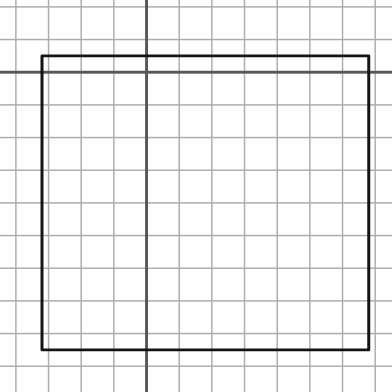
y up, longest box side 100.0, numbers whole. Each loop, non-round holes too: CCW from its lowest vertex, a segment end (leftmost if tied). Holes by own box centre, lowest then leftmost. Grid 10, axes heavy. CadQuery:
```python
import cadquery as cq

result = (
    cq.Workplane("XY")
    .moveTo(-32.0, -85.0)
    .lineTo(68.0, -85.0)
    .lineTo(68.0, 5.0)
    .lineTo(-32.0, 5.0)
    .close()
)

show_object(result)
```